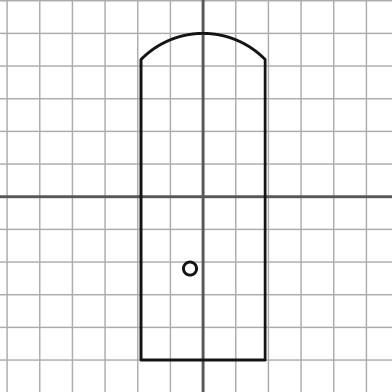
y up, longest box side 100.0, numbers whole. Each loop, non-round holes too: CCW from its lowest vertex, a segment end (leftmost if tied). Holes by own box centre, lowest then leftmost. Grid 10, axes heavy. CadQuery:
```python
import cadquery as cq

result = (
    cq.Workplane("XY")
    .moveTo(-19.0, -50.0)
    .lineTo(19.0, -50.0)
    .lineTo(19.0, 42.0)
    .threePointArc((0.0, 50.0), (-19.0, 42.0))
    .close()
    .moveTo(-4.0, -22.0)
    .circle(2.0)
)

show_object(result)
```